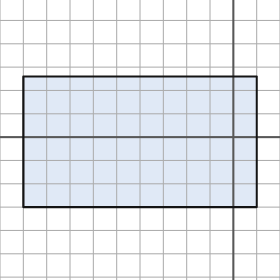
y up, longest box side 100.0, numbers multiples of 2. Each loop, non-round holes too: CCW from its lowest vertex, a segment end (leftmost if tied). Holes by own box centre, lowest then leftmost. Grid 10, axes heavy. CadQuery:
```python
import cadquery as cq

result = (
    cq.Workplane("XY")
    .moveTo(-90.0, -30.0)
    .lineTo(10.0, -30.0)
    .lineTo(10.0, 26.0)
    .lineTo(-90.0, 26.0)
    .close()
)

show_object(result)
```